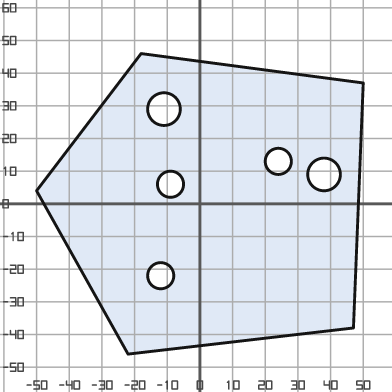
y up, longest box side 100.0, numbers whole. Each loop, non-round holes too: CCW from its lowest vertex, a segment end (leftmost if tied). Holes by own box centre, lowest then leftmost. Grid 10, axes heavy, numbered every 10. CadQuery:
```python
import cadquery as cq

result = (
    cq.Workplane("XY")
    .moveTo(-22.0, -46.0)
    .lineTo(47.0, -38.0)
    .lineTo(50.0, 37.0)
    .lineTo(-18.0, 46.0)
    .lineTo(-50.0, 4.0)
    .close()
    .moveTo(-12.0, -22.0)
    .circle(4.0)
    .moveTo(-9.0, 6.0)
    .circle(4.0)
    .moveTo(38.0, 9.0)
    .circle(5.0)
    .moveTo(24.0, 13.0)
    .circle(4.0)
    .moveTo(-11.0, 29.0)
    .circle(5.0)
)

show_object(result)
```